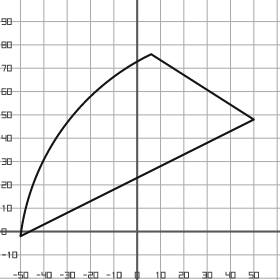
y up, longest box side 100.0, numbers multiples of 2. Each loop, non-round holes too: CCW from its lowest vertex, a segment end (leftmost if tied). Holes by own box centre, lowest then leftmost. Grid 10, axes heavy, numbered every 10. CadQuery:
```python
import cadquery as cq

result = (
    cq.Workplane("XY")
    .moveTo(-50.0, -2.0)
    .lineTo(50.0, 48.0)
    .lineTo(6.0, 76.0)
    .threePointArc((-32.0, 44.0), (-50.0, -2.0))
    .close()
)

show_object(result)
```